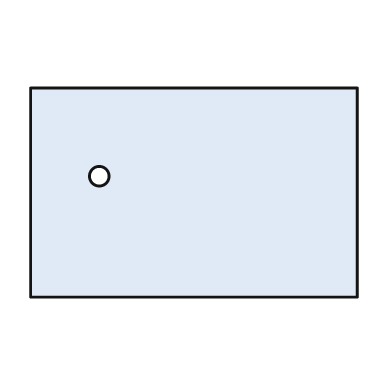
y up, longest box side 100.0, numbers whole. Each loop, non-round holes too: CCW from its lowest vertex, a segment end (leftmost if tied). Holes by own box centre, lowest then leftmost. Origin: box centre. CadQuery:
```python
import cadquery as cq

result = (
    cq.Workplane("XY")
    .moveTo(-50.0, -32.0)
    .lineTo(50.0, -32.0)
    .lineTo(50.0, 32.0)
    .lineTo(-50.0, 32.0)
    .close()
    .moveTo(-29.0, 5.0)
    .circle(3.0)
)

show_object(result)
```